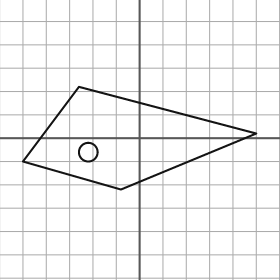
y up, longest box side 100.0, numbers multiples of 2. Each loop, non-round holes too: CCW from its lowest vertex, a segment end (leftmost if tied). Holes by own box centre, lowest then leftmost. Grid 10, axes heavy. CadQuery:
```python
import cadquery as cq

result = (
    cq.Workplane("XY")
    .moveTo(-8.0, -22.0)
    .lineTo(50.0, 2.0)
    .lineTo(-26.0, 22.0)
    .lineTo(-50.0, -10.0)
    .close()
    .moveTo(-22.0, -6.0)
    .circle(4.0)
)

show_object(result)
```